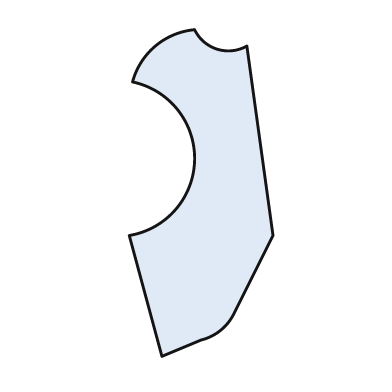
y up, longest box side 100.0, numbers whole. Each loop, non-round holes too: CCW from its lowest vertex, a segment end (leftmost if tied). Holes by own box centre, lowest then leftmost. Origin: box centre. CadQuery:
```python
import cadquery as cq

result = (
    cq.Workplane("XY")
    .moveTo(-12.0, -50.0)
    .lineTo(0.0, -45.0)
    .threePointArc((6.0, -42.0), (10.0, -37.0))
    .lineTo(22.0, -13.0)
    .lineTo(14.0, 45.0)
    .threePointArc((5.0, 44.0), (-2.0, 50.0))
    .threePointArc((-14.0, 45.0), (-21.0, 34.0))
    .threePointArc((-2.0, 10.0), (-22.0, -13.0))
    .close()
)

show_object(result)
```